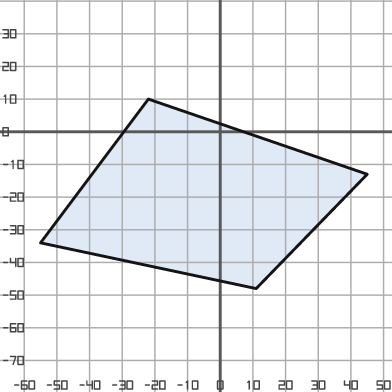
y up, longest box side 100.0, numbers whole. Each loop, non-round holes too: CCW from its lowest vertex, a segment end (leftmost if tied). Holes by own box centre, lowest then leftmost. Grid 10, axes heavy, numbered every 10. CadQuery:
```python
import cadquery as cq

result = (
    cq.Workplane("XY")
    .moveTo(11.0, -48.0)
    .lineTo(45.0, -13.0)
    .lineTo(-22.0, 10.0)
    .lineTo(-55.0, -34.0)
    .close()
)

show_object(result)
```